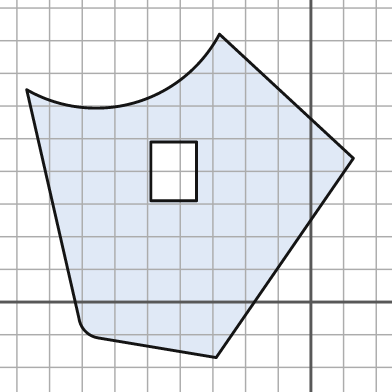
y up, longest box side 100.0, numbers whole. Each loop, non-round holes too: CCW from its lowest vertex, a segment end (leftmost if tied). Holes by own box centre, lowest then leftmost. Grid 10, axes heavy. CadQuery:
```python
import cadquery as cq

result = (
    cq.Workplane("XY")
    .moveTo(-29.0, -17.0)
    .lineTo(13.0, 44.0)
    .lineTo(-28.0, 82.0)
    .threePointArc((-54.0, 61.0), (-87.0, 65.0))
    .lineTo(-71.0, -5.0)
    .threePointArc((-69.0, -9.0), (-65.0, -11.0))
    .close()
    .moveTo(-49.0, 31.0)
    .lineTo(-35.0, 31.0)
    .lineTo(-35.0, 49.0)
    .lineTo(-49.0, 49.0)
    .close()
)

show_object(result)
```